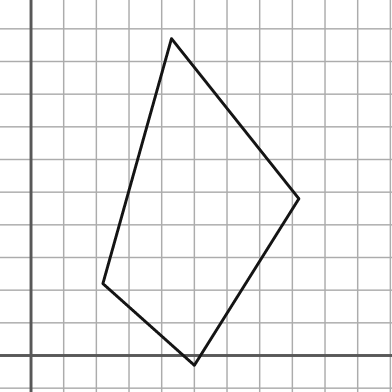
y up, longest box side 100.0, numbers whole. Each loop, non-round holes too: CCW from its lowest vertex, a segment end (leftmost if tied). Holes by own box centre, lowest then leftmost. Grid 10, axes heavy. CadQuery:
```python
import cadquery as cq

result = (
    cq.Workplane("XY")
    .moveTo(50.0, -3.0)
    .lineTo(82.0, 48.0)
    .lineTo(43.0, 97.0)
    .lineTo(22.0, 22.0)
    .close()
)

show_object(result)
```